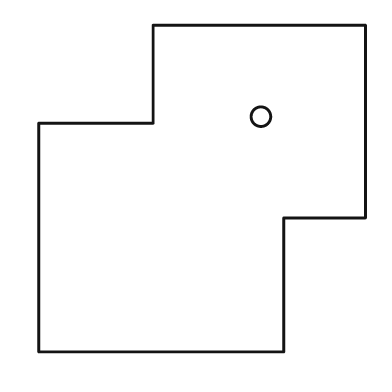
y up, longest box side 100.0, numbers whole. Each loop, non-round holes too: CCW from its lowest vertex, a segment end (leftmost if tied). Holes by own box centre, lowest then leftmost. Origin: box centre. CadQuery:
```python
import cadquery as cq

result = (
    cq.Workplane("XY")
    .moveTo(-50.0, -50.0)
    .lineTo(25.0, -50.0)
    .lineTo(25.0, -9.0)
    .lineTo(50.0, -9.0)
    .lineTo(50.0, 50.0)
    .lineTo(-15.0, 50.0)
    .lineTo(-15.0, 20.0)
    .lineTo(-50.0, 20.0)
    .close()
    .moveTo(18.0, 22.0)
    .circle(3.0)
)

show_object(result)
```